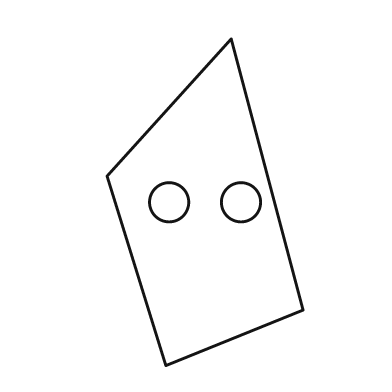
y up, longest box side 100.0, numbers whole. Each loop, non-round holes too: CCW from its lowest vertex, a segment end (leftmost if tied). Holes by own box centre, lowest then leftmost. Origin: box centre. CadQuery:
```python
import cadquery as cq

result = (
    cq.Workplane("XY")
    .moveTo(-12.0, -50.0)
    .lineTo(30.0, -33.0)
    .lineTo(8.0, 50.0)
    .lineTo(-30.0, 8.0)
    .close()
    .moveTo(-11.0, 0.0)
    .circle(6.0)
    .moveTo(11.0, 0.0)
    .circle(6.0)
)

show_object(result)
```